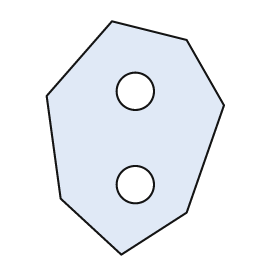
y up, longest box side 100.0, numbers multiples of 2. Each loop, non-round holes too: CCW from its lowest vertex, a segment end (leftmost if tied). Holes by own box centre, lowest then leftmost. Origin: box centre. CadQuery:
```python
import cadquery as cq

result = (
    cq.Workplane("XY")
    .moveTo(-6.0, -50.0)
    .lineTo(22.0, -32.0)
    .lineTo(38.0, 14.0)
    .lineTo(22.0, 42.0)
    .lineTo(-10.0, 50.0)
    .lineTo(-38.0, 18.0)
    .lineTo(-32.0, -26.0)
    .close()
    .moveTo(0.0, -20.0)
    .circle(8.0)
    .moveTo(0.0, 20.0)
    .circle(8.0)
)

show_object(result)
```